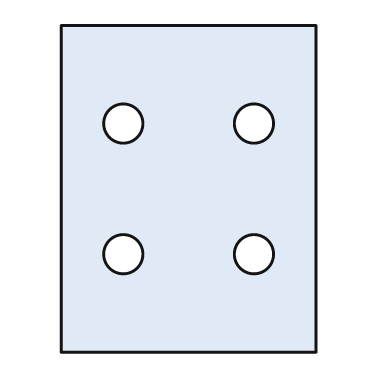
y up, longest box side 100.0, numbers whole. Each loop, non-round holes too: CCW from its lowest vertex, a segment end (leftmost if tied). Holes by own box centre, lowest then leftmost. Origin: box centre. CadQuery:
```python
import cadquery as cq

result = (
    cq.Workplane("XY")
    .moveTo(-39.0, -50.0)
    .lineTo(39.0, -50.0)
    .lineTo(39.0, 50.0)
    .lineTo(-39.0, 50.0)
    .close()
    .moveTo(-20.0, -20.0)
    .circle(6.0)
    .moveTo(20.0, -20.0)
    .circle(6.0)
    .moveTo(-20.0, 20.0)
    .circle(6.0)
    .moveTo(20.0, 20.0)
    .circle(6.0)
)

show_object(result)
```